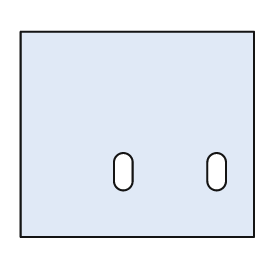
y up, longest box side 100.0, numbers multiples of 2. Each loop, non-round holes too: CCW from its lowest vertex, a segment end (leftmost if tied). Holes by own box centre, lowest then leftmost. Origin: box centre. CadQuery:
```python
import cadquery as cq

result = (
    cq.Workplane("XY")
    .moveTo(-50.0, -44.0)
    .lineTo(50.0, -44.0)
    .lineTo(50.0, 44.0)
    .lineTo(-50.0, 44.0)
    .close()
    .moveTo(-10.0, -20.0)
    .threePointArc((-6.0, -24.0), (-2.0, -20.0))
    .lineTo(-2.0, -12.0)
    .threePointArc((-6.0, -8.0), (-10.0, -12.0))
    .close()
    .moveTo(30.0, -20.0)
    .threePointArc((34.0, -24.0), (38.0, -20.0))
    .lineTo(38.0, -12.0)
    .threePointArc((34.0, -8.0), (30.0, -12.0))
    .close()
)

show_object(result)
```